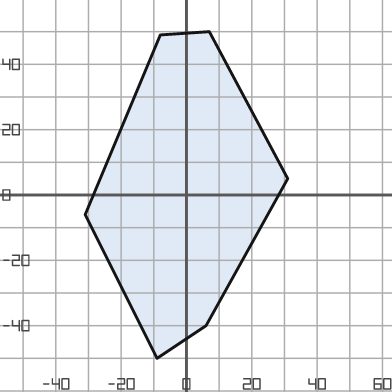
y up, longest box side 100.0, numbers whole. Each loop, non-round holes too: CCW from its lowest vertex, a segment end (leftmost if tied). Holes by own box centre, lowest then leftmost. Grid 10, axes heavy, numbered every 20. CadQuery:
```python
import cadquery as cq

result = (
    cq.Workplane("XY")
    .moveTo(-9.0, -50.0)
    .lineTo(6.0, -40.0)
    .lineTo(31.0, 5.0)
    .lineTo(7.0, 50.0)
    .lineTo(-8.0, 49.0)
    .lineTo(-31.0, -6.0)
    .close()
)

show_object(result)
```